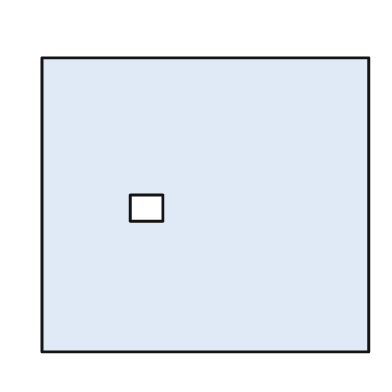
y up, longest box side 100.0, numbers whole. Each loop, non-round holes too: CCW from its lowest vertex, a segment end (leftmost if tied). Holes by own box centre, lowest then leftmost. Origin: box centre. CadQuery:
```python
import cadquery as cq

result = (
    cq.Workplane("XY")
    .moveTo(-50.0, -45.0)
    .lineTo(50.0, -45.0)
    .lineTo(50.0, 45.0)
    .lineTo(-50.0, 45.0)
    .close()
    .moveTo(-23.0, -5.0)
    .lineTo(-13.0, -5.0)
    .lineTo(-13.0, 3.0)
    .lineTo(-23.0, 3.0)
    .close()
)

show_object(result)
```